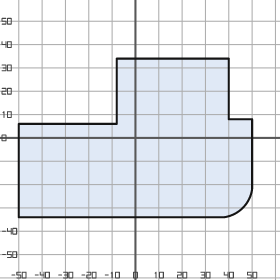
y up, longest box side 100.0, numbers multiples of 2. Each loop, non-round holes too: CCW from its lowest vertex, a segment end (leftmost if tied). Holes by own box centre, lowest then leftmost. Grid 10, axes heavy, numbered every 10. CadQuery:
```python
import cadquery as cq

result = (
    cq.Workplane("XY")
    .moveTo(-50.0, -34.0)
    .lineTo(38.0, -34.0)
    .threePointArc((46.0, -30.0), (50.0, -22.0))
    .lineTo(50.0, 8.0)
    .lineTo(40.0, 8.0)
    .lineTo(40.0, 34.0)
    .lineTo(-8.0, 34.0)
    .lineTo(-8.0, 6.0)
    .lineTo(-50.0, 6.0)
    .close()
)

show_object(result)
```